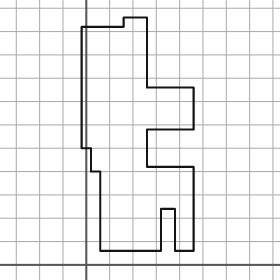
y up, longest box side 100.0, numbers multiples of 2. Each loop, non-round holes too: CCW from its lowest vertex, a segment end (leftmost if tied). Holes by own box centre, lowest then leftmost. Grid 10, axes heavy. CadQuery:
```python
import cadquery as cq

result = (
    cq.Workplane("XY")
    .moveTo(6.0, 6.0)
    .lineTo(32.0, 6.0)
    .lineTo(32.0, 24.0)
    .lineTo(38.0, 24.0)
    .lineTo(38.0, 6.0)
    .lineTo(46.0, 6.0)
    .lineTo(46.0, 42.0)
    .lineTo(26.0, 42.0)
    .lineTo(26.0, 58.0)
    .lineTo(46.0, 58.0)
    .lineTo(46.0, 76.0)
    .lineTo(26.0, 76.0)
    .lineTo(26.0, 106.0)
    .lineTo(16.0, 106.0)
    .lineTo(16.0, 102.0)
    .lineTo(-2.0, 102.0)
    .lineTo(-2.0, 50.0)
    .lineTo(2.0, 50.0)
    .lineTo(2.0, 40.0)
    .lineTo(6.0, 40.0)
    .close()
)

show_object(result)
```